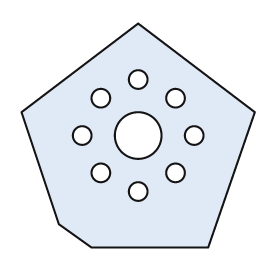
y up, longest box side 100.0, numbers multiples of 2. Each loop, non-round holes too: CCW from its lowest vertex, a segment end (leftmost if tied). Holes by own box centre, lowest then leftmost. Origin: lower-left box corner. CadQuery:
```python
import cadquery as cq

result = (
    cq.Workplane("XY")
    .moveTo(30.0, 0.0)
    .lineTo(80.0, 0.0)
    .lineTo(100.0, 58.0)
    .lineTo(50.0, 96.0)
    .lineTo(0.0, 58.0)
    .lineTo(16.0, 10.0)
    .close()
    .moveTo(50.0, 24.0)
    .circle(4.0)
    .moveTo(34.0, 32.0)
    .circle(4.0)
    .moveTo(66.0, 32.0)
    .circle(4.0)
    .moveTo(26.0, 48.0)
    .circle(4.0)
    .moveTo(50.0, 48.0)
    .circle(10.0)
    .moveTo(74.0, 48.0)
    .circle(4.0)
    .moveTo(34.0, 64.0)
    .circle(4.0)
    .moveTo(66.0, 64.0)
    .circle(4.0)
    .moveTo(50.0, 72.0)
    .circle(4.0)
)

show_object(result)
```